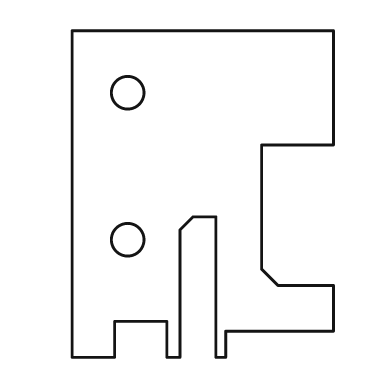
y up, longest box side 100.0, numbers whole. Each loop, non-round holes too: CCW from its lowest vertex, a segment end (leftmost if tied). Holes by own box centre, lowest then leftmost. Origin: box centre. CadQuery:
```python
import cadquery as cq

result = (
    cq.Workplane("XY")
    .moveTo(-40.0, -50.0)
    .lineTo(-27.0, -50.0)
    .lineTo(-27.0, -39.0)
    .lineTo(-11.0, -39.0)
    .lineTo(-11.0, -50.0)
    .lineTo(-7.0, -50.0)
    .lineTo(-7.0, -11.0)
    .lineTo(-3.0, -7.0)
    .lineTo(4.0, -7.0)
    .lineTo(4.0, -50.0)
    .lineTo(7.0, -50.0)
    .lineTo(7.0, -42.0)
    .lineTo(40.0, -42.0)
    .lineTo(40.0, -28.0)
    .lineTo(23.0, -28.0)
    .lineTo(18.0, -23.0)
    .lineTo(18.0, 15.0)
    .lineTo(40.0, 15.0)
    .lineTo(40.0, 50.0)
    .lineTo(-40.0, 50.0)
    .close()
    .moveTo(-23.0, -14.0)
    .circle(5.0)
    .moveTo(-23.0, 31.0)
    .circle(5.0)
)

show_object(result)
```